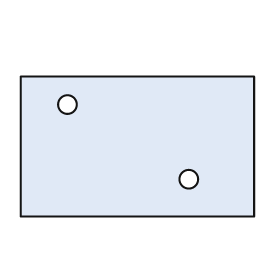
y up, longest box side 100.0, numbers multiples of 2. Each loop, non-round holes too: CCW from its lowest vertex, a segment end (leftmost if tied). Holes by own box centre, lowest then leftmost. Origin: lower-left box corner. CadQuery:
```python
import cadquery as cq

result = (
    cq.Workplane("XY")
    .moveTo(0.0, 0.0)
    .lineTo(100.0, 0.0)
    .lineTo(100.0, 60.0)
    .lineTo(0.0, 60.0)
    .close()
    .moveTo(72.0, 16.0)
    .circle(4.0)
    .moveTo(20.0, 48.0)
    .circle(4.0)
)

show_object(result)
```